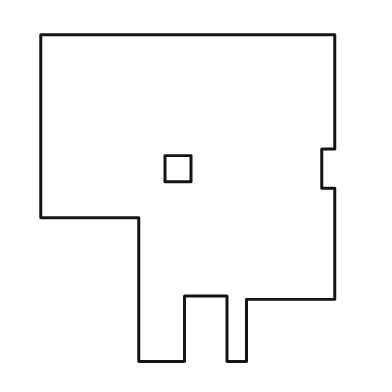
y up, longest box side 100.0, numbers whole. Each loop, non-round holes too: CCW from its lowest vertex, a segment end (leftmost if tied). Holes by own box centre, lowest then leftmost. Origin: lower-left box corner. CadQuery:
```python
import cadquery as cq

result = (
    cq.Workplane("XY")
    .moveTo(30.0, 0.0)
    .lineTo(44.0, 0.0)
    .lineTo(44.0, 20.0)
    .lineTo(57.0, 20.0)
    .lineTo(57.0, 0.0)
    .lineTo(63.0, 0.0)
    .lineTo(63.0, 19.0)
    .lineTo(90.0, 19.0)
    .lineTo(90.0, 53.0)
    .lineTo(86.0, 53.0)
    .lineTo(86.0, 65.0)
    .lineTo(90.0, 65.0)
    .lineTo(90.0, 100.0)
    .lineTo(0.0, 100.0)
    .lineTo(0.0, 44.0)
    .lineTo(30.0, 44.0)
    .close()
    .moveTo(38.0, 55.0)
    .lineTo(46.0, 55.0)
    .lineTo(46.0, 63.0)
    .lineTo(38.0, 63.0)
    .close()
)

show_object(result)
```